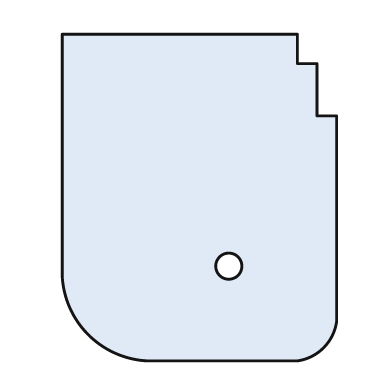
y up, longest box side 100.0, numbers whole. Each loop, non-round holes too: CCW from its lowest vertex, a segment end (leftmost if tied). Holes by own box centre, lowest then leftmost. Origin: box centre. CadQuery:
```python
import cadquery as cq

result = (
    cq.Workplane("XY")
    .moveTo(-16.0, -50.0)
    .lineTo(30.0, -50.0)
    .threePointArc((38.0, -46.0), (42.0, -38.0))
    .lineTo(42.0, 25.0)
    .lineTo(36.0, 25.0)
    .lineTo(36.0, 41.0)
    .lineTo(30.0, 41.0)
    .lineTo(30.0, 50.0)
    .lineTo(-42.0, 50.0)
    .lineTo(-42.0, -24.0)
    .threePointArc((-34.0, -42.0), (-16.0, -50.0))
    .close()
    .moveTo(9.0, -21.0)
    .circle(4.0)
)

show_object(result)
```